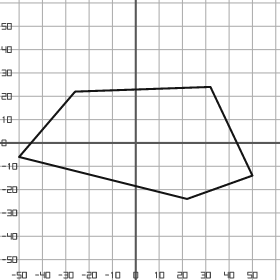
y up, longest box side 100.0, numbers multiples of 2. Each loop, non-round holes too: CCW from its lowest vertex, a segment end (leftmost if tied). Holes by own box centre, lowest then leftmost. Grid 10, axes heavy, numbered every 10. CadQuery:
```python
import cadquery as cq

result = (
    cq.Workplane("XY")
    .moveTo(22.0, -24.0)
    .lineTo(50.0, -14.0)
    .lineTo(32.0, 24.0)
    .lineTo(-26.0, 22.0)
    .lineTo(-50.0, -6.0)
    .close()
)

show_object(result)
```